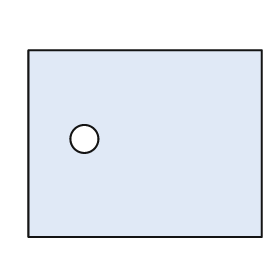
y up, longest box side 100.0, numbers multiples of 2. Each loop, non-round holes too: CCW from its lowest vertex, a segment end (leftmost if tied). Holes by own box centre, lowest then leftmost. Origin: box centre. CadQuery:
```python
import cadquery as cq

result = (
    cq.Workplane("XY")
    .moveTo(-50.0, -40.0)
    .lineTo(50.0, -40.0)
    .lineTo(50.0, 40.0)
    .lineTo(-50.0, 40.0)
    .close()
    .moveTo(-26.0, 2.0)
    .circle(6.0)
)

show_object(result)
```